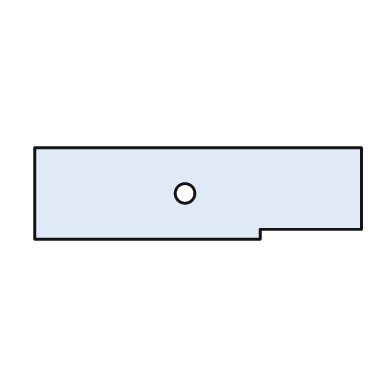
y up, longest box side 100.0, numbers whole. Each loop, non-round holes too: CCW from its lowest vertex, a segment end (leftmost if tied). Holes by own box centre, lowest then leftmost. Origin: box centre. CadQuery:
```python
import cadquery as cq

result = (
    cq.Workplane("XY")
    .moveTo(-50.0, -14.0)
    .lineTo(19.0, -14.0)
    .lineTo(19.0, -11.0)
    .lineTo(50.0, -11.0)
    .lineTo(50.0, 14.0)
    .lineTo(-50.0, 14.0)
    .close()
    .moveTo(-4.0, 0.0)
    .circle(3.0)
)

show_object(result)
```